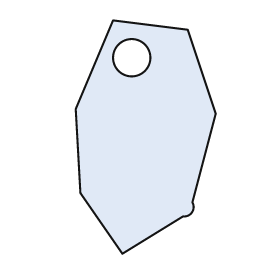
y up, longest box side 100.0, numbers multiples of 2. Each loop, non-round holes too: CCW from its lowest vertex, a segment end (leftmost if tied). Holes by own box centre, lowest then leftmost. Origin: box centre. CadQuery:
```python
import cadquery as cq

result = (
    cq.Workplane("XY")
    .moveTo(-10.0, -50.0)
    .lineTo(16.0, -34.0)
    .threePointArc((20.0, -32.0), (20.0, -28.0))
    .lineTo(30.0, 10.0)
    .lineTo(18.0, 46.0)
    .lineTo(-14.0, 50.0)
    .lineTo(-30.0, 12.0)
    .lineTo(-28.0, -24.0)
    .close()
    .moveTo(-6.0, 34.0)
    .circle(8.0)
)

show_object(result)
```